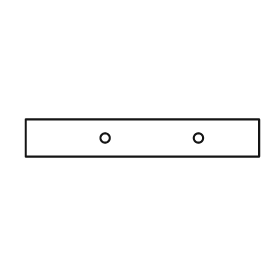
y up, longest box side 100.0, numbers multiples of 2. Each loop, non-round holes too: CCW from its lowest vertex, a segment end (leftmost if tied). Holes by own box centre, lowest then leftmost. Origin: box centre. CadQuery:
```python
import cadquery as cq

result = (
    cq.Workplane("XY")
    .moveTo(-50.0, -8.0)
    .lineTo(50.0, -8.0)
    .lineTo(50.0, 8.0)
    .lineTo(-50.0, 8.0)
    .close()
    .moveTo(-16.0, 0.0)
    .circle(2.0)
    .moveTo(24.0, 0.0)
    .circle(2.0)
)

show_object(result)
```